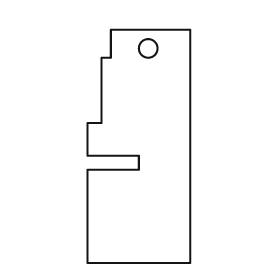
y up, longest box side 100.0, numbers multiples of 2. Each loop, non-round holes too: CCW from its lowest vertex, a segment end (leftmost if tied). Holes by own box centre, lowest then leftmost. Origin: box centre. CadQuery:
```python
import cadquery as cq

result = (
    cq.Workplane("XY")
    .moveTo(-22.0, -50.0)
    .lineTo(22.0, -50.0)
    .lineTo(22.0, 50.0)
    .lineTo(-12.0, 50.0)
    .lineTo(-12.0, 38.0)
    .lineTo(-16.0, 38.0)
    .lineTo(-16.0, 10.0)
    .lineTo(-22.0, 10.0)
    .lineTo(-22.0, -4.0)
    .lineTo(0.0, -4.0)
    .lineTo(0.0, -10.0)
    .lineTo(-22.0, -10.0)
    .close()
    .moveTo(4.0, 42.0)
    .circle(4.0)
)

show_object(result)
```